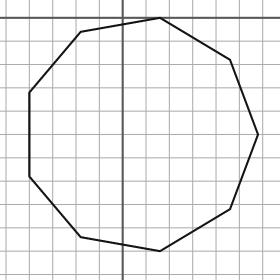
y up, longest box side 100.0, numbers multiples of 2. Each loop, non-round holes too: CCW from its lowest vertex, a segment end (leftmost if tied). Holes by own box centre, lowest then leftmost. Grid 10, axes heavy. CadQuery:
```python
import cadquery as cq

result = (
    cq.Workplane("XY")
    .moveTo(16.0, -100.0)
    .lineTo(46.0, -82.0)
    .lineTo(58.0, -50.0)
    .lineTo(46.0, -18.0)
    .lineTo(16.0, 0.0)
    .lineTo(-18.0, -6.0)
    .lineTo(-40.0, -32.0)
    .lineTo(-40.0, -68.0)
    .lineTo(-18.0, -94.0)
    .close()
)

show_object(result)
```